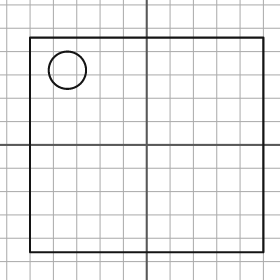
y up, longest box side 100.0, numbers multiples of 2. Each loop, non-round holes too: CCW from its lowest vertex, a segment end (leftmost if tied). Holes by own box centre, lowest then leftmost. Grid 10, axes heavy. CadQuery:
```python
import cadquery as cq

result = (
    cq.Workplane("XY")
    .moveTo(-50.0, -46.0)
    .lineTo(50.0, -46.0)
    .lineTo(50.0, 46.0)
    .lineTo(-50.0, 46.0)
    .close()
    .moveTo(-34.0, 32.0)
    .circle(8.0)
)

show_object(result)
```